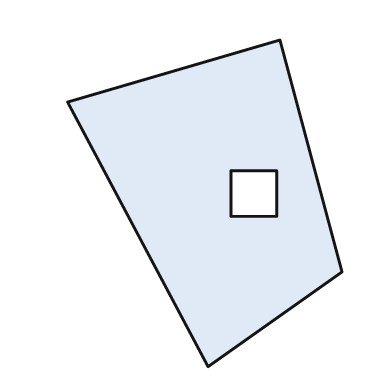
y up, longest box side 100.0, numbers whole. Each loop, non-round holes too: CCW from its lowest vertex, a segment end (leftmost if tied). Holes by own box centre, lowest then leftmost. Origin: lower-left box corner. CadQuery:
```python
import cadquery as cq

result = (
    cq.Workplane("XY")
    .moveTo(43.0, 0.0)
    .lineTo(84.0, 29.0)
    .lineTo(65.0, 100.0)
    .lineTo(0.0, 81.0)
    .close()
    .moveTo(50.0, 46.0)
    .lineTo(64.0, 46.0)
    .lineTo(64.0, 60.0)
    .lineTo(50.0, 60.0)
    .close()
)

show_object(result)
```